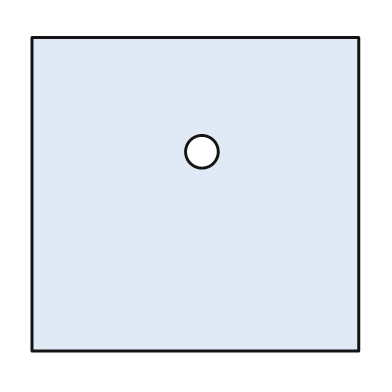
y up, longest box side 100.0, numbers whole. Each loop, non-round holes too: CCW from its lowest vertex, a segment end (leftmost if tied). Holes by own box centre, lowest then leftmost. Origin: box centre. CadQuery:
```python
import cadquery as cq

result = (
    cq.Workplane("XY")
    .moveTo(-50.0, -48.0)
    .lineTo(50.0, -48.0)
    .lineTo(50.0, 48.0)
    .lineTo(-50.0, 48.0)
    .close()
    .moveTo(2.0, 13.0)
    .circle(5.0)
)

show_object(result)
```